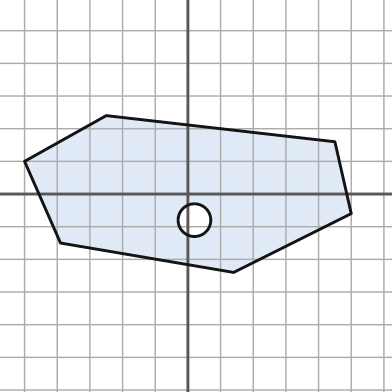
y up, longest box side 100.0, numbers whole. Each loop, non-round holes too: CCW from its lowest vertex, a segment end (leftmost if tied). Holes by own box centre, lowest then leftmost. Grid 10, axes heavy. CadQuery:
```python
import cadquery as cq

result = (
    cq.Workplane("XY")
    .moveTo(14.0, -24.0)
    .lineTo(50.0, -6.0)
    .lineTo(45.0, 16.0)
    .lineTo(-25.0, 24.0)
    .lineTo(-50.0, 10.0)
    .lineTo(-39.0, -15.0)
    .close()
    .moveTo(2.0, -8.0)
    .circle(5.0)
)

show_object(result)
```